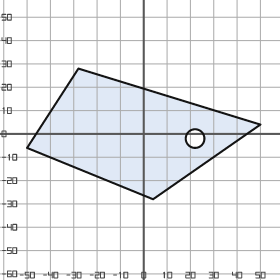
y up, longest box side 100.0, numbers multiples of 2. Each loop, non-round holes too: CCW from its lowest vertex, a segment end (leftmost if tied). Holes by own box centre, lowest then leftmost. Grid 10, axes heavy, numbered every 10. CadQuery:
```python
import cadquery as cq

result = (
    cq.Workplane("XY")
    .moveTo(4.0, -28.0)
    .lineTo(50.0, 4.0)
    .lineTo(-28.0, 28.0)
    .lineTo(-50.0, -6.0)
    .close()
    .moveTo(22.0, -2.0)
    .circle(4.0)
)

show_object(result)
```